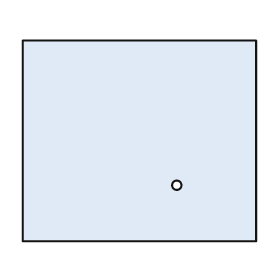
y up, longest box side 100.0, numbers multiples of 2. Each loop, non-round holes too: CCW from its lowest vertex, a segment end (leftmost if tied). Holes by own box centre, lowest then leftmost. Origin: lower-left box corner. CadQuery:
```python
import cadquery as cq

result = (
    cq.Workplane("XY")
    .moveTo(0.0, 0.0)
    .lineTo(100.0, 0.0)
    .lineTo(100.0, 86.0)
    .lineTo(0.0, 86.0)
    .close()
    .moveTo(66.0, 24.0)
    .circle(2.0)
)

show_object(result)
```